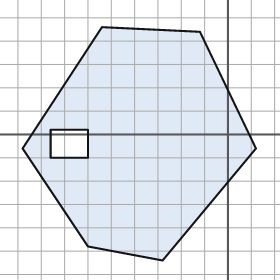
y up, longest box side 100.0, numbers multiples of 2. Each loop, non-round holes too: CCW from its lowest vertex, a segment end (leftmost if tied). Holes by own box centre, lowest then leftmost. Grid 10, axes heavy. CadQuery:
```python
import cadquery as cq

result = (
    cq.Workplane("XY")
    .moveTo(-28.0, -54.0)
    .lineTo(12.0, -6.0)
    .lineTo(-12.0, 44.0)
    .lineTo(-54.0, 46.0)
    .lineTo(-88.0, -6.0)
    .lineTo(-60.0, -48.0)
    .close()
    .moveTo(-76.0, -10.0)
    .lineTo(-60.0, -10.0)
    .lineTo(-60.0, 2.0)
    .lineTo(-76.0, 2.0)
    .close()
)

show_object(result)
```